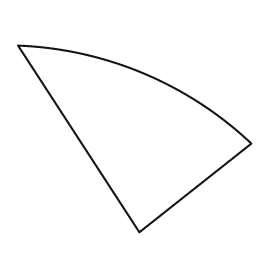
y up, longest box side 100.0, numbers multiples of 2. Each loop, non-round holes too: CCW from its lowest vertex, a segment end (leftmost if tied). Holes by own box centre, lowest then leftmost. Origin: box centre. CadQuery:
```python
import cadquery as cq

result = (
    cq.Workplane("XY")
    .moveTo(2.0, -40.0)
    .lineTo(50.0, -2.0)
    .threePointArc((4.0, 28.0), (-50.0, 40.0))
    .close()
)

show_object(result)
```